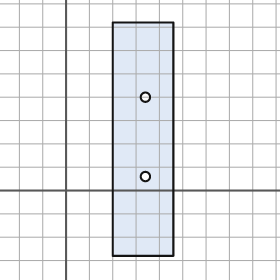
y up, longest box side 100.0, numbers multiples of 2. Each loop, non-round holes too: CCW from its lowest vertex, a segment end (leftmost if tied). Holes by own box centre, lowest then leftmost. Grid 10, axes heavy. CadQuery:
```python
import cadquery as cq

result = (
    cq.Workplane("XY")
    .moveTo(20.0, -28.0)
    .lineTo(46.0, -28.0)
    .lineTo(46.0, 72.0)
    .lineTo(20.0, 72.0)
    .close()
    .moveTo(34.0, 6.0)
    .circle(2.0)
    .moveTo(34.0, 40.0)
    .circle(2.0)
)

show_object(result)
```